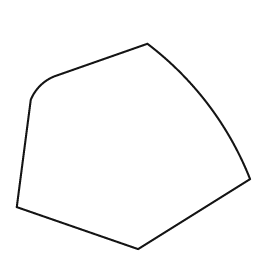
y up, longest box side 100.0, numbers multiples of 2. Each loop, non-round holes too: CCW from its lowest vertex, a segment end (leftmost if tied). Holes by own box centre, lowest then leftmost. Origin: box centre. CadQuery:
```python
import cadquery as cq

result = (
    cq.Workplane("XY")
    .moveTo(2.0, -44.0)
    .lineTo(50.0, -14.0)
    .threePointArc((32.0, 18.0), (6.0, 44.0))
    .lineTo(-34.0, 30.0)
    .threePointArc((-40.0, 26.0), (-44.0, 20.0))
    .lineTo(-50.0, -26.0)
    .close()
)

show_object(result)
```